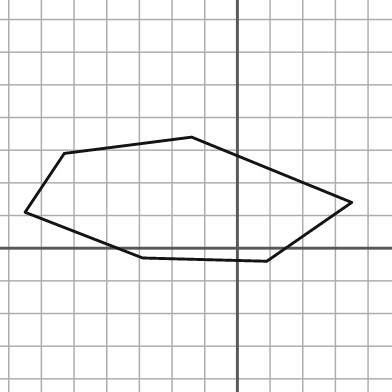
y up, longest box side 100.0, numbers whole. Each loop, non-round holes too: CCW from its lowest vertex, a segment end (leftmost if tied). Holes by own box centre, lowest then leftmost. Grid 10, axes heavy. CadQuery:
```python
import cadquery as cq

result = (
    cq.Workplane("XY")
    .moveTo(9.0, -4.0)
    .lineTo(35.0, 14.0)
    .lineTo(-14.0, 34.0)
    .lineTo(-53.0, 29.0)
    .lineTo(-65.0, 11.0)
    .lineTo(-29.0, -3.0)
    .close()
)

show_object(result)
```